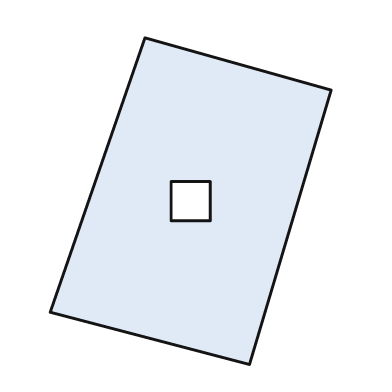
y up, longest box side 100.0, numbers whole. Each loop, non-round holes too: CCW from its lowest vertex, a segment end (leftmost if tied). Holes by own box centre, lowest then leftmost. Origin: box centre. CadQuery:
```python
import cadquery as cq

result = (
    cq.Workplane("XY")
    .moveTo(18.0, -50.0)
    .lineTo(43.0, 34.0)
    .lineTo(-14.0, 50.0)
    .lineTo(-43.0, -34.0)
    .close()
    .moveTo(-6.0, -6.0)
    .lineTo(6.0, -6.0)
    .lineTo(6.0, 6.0)
    .lineTo(-6.0, 6.0)
    .close()
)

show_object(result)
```